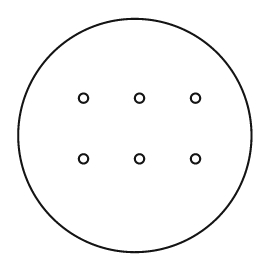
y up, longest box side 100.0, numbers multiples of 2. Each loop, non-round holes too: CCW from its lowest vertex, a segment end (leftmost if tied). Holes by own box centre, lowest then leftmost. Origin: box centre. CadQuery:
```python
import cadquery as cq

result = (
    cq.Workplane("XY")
    .moveTo(0.0, 0.0)
    .circle(50.0)
    .moveTo(-22.0, -10.0)
    .circle(2.0)
    .moveTo(2.0, -10.0)
    .circle(2.0)
    .moveTo(26.0, -10.0)
    .circle(2.0)
    .moveTo(-22.0, 16.0)
    .circle(2.0)
    .moveTo(2.0, 16.0)
    .circle(2.0)
    .moveTo(26.0, 16.0)
    .circle(2.0)
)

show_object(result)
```